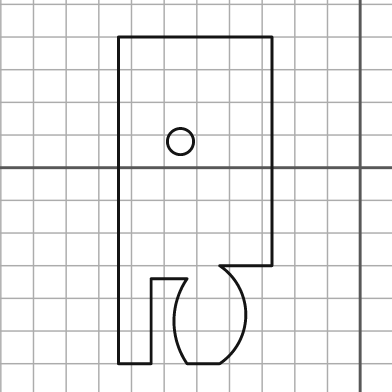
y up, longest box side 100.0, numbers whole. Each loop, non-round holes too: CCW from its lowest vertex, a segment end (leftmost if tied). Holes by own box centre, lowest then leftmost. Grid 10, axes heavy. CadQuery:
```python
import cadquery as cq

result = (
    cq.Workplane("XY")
    .moveTo(-74.0, -60.0)
    .lineTo(-64.0, -60.0)
    .lineTo(-64.0, -34.0)
    .lineTo(-53.0, -34.0)
    .threePointArc((-57.0, -47.0), (-53.0, -60.0))
    .lineTo(-43.0, -60.0)
    .threePointArc((-35.0, -45.0), (-43.0, -30.0))
    .lineTo(-27.0, -30.0)
    .lineTo(-27.0, 40.0)
    .lineTo(-74.0, 40.0)
    .close()
    .moveTo(-55.0, 8.0)
    .circle(4.0)
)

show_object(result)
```